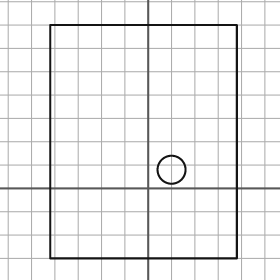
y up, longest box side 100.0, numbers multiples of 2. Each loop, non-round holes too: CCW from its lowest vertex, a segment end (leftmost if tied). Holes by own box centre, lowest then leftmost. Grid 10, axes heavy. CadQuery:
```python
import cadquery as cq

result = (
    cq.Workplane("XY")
    .moveTo(-42.0, -30.0)
    .lineTo(38.0, -30.0)
    .lineTo(38.0, 70.0)
    .lineTo(-42.0, 70.0)
    .close()
    .moveTo(10.0, 8.0)
    .circle(6.0)
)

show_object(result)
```